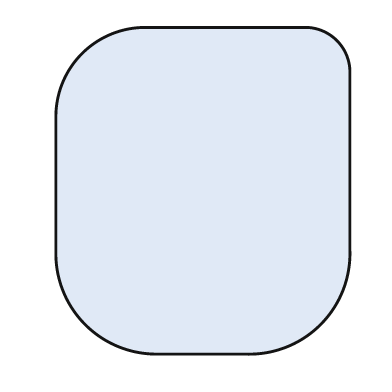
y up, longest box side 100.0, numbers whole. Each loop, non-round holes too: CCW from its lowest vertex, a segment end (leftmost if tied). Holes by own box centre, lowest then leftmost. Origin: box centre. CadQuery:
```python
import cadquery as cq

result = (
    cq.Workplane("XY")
    .moveTo(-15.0, -50.0)
    .lineTo(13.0, -50.0)
    .threePointArc((36.0, -41.0), (45.0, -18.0))
    .lineTo(45.0, 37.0)
    .threePointArc((41.0, 46.0), (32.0, 50.0))
    .lineTo(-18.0, 50.0)
    .threePointArc((-37.0, 42.0), (-45.0, 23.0))
    .lineTo(-45.0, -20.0)
    .threePointArc((-36.0, -41.0), (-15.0, -50.0))
    .close()
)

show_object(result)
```